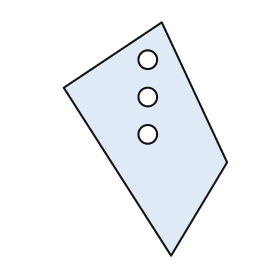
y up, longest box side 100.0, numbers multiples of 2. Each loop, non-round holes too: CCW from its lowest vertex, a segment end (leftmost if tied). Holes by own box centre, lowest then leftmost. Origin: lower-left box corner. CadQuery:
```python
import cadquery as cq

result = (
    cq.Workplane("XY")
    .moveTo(46.0, 0.0)
    .lineTo(70.0, 40.0)
    .lineTo(42.0, 100.0)
    .lineTo(0.0, 72.0)
    .close()
    .moveTo(36.0, 52.0)
    .circle(4.0)
    .moveTo(36.0, 68.0)
    .circle(4.0)
    .moveTo(36.0, 84.0)
    .circle(4.0)
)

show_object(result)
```